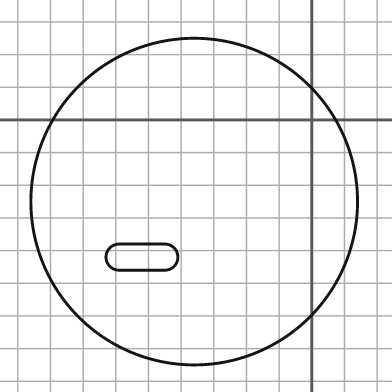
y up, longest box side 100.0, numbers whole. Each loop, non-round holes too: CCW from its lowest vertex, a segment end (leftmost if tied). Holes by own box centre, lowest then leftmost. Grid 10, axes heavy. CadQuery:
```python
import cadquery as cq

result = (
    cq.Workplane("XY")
    .moveTo(-36.0, -25.0)
    .circle(50.0)
    .moveTo(-59.0, -46.0)
    .lineTo(-45.0, -46.0)
    .threePointArc((-41.0, -42.0), (-45.0, -38.0))
    .lineTo(-59.0, -38.0)
    .threePointArc((-63.0, -42.0), (-59.0, -46.0))
    .close()
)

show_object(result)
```